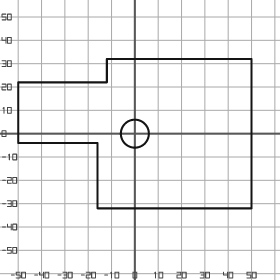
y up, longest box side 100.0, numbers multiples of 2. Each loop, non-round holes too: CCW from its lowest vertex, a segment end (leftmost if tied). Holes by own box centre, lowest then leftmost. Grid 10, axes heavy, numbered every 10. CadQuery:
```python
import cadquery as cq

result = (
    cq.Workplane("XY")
    .moveTo(-16.0, -32.0)
    .lineTo(50.0, -32.0)
    .lineTo(50.0, 32.0)
    .lineTo(-12.0, 32.0)
    .lineTo(-12.0, 22.0)
    .lineTo(-50.0, 22.0)
    .lineTo(-50.0, -4.0)
    .lineTo(-16.0, -4.0)
    .close()
    .moveTo(0.0, 0.0)
    .circle(6.0)
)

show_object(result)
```